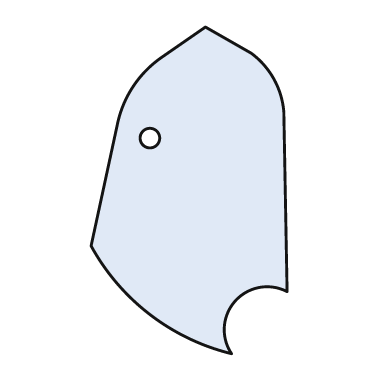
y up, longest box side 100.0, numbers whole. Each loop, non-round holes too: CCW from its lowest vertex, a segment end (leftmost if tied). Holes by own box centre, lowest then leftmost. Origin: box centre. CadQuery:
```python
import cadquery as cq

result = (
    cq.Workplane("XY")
    .moveTo(13.0, -50.0)
    .threePointArc((14.0, -34.0), (30.0, -31.0))
    .lineTo(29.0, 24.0)
    .threePointArc((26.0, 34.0), (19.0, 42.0))
    .lineTo(5.0, 50.0)
    .lineTo(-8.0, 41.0)
    .threePointArc((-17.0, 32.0), (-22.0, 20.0))
    .lineTo(-30.0, -17.0)
    .threePointArc((-12.0, -38.0), (13.0, -50.0))
    .close()
    .moveTo(-12.0, 16.0)
    .circle(3.0)
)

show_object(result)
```